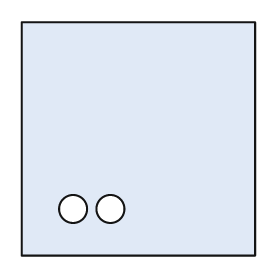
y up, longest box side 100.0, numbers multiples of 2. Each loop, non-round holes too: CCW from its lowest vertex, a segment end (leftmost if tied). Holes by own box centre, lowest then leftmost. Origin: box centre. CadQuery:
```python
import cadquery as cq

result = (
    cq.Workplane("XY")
    .moveTo(-50.0, -50.0)
    .lineTo(50.0, -50.0)
    .lineTo(50.0, 50.0)
    .lineTo(-50.0, 50.0)
    .close()
    .moveTo(-28.0, -30.0)
    .circle(6.0)
    .moveTo(-12.0, -30.0)
    .circle(6.0)
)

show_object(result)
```